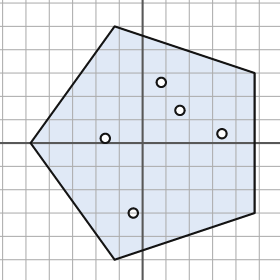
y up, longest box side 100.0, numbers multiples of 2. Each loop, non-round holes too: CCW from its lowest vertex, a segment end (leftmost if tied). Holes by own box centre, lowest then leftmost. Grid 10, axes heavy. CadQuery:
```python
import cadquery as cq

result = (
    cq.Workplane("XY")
    .moveTo(-12.0, -50.0)
    .lineTo(48.0, -30.0)
    .lineTo(48.0, 30.0)
    .lineTo(-12.0, 50.0)
    .lineTo(-48.0, 0.0)
    .close()
    .moveTo(-4.0, -30.0)
    .circle(2.0)
    .moveTo(-16.0, 2.0)
    .circle(2.0)
    .moveTo(34.0, 4.0)
    .circle(2.0)
    .moveTo(16.0, 14.0)
    .circle(2.0)
    .moveTo(8.0, 26.0)
    .circle(2.0)
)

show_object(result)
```